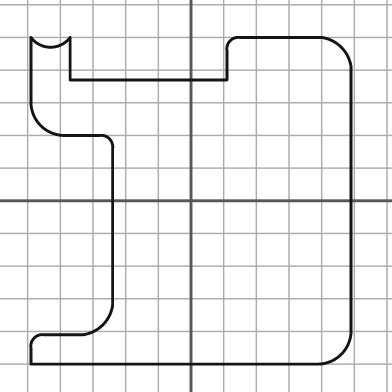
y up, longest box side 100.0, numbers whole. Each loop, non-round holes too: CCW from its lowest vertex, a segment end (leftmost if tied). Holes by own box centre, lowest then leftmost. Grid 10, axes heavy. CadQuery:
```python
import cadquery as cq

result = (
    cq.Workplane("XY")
    .moveTo(-49.0, -50.0)
    .lineTo(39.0, -50.0)
    .threePointArc((46.0, -47.0), (49.0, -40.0))
    .lineTo(49.0, 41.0)
    .threePointArc((46.0, 47.0), (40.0, 50.0))
    .lineTo(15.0, 50.0)
    .threePointArc((12.0, 49.0), (11.0, 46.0))
    .lineTo(11.0, 37.0)
    .lineTo(-37.0, 37.0)
    .lineTo(-37.0, 50.0)
    .threePointArc((-43.0, 47.0), (-49.0, 50.0))
    .lineTo(-49.0, 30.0)
    .threePointArc((-46.0, 23.0), (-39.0, 20.0))
    .lineTo(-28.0, 20.0)
    .threePointArc((-25.0, 19.0), (-24.0, 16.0))
    .lineTo(-24.0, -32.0)
    .threePointArc((-27.0, -38.0), (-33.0, -41.0))
    .lineTo(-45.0, -41.0)
    .threePointArc((-48.0, -42.0), (-49.0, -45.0))
    .close()
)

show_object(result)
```